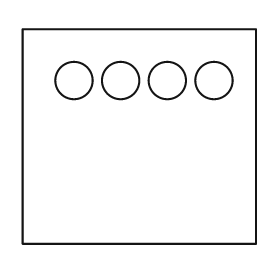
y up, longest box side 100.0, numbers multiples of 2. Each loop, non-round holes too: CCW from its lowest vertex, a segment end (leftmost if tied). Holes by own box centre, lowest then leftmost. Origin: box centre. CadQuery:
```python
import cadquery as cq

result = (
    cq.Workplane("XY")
    .moveTo(-50.0, -46.0)
    .lineTo(50.0, -46.0)
    .lineTo(50.0, 46.0)
    .lineTo(-50.0, 46.0)
    .close()
    .moveTo(-28.0, 24.0)
    .circle(8.0)
    .moveTo(-8.0, 24.0)
    .circle(8.0)
    .moveTo(12.0, 24.0)
    .circle(8.0)
    .moveTo(32.0, 24.0)
    .circle(8.0)
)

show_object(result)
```